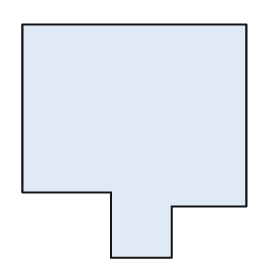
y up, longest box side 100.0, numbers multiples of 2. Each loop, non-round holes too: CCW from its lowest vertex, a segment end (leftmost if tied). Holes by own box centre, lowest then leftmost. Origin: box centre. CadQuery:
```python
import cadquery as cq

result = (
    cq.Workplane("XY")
    .moveTo(-10.0, -50.0)
    .lineTo(16.0, -50.0)
    .lineTo(16.0, -28.0)
    .lineTo(48.0, -28.0)
    .lineTo(48.0, 50.0)
    .lineTo(-48.0, 50.0)
    .lineTo(-48.0, -22.0)
    .lineTo(-10.0, -22.0)
    .close()
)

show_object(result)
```